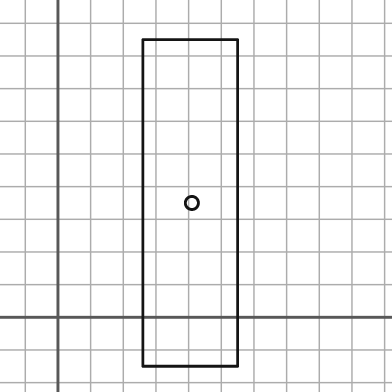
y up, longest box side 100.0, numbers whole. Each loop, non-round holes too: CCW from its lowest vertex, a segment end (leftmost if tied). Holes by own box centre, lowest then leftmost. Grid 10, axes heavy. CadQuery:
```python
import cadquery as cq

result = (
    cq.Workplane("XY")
    .moveTo(26.0, -15.0)
    .lineTo(55.0, -15.0)
    .lineTo(55.0, 85.0)
    .lineTo(26.0, 85.0)
    .close()
    .moveTo(41.0, 35.0)
    .circle(2.0)
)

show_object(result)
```